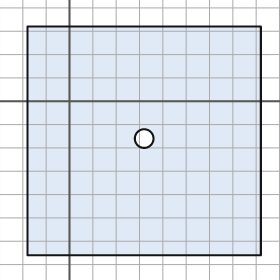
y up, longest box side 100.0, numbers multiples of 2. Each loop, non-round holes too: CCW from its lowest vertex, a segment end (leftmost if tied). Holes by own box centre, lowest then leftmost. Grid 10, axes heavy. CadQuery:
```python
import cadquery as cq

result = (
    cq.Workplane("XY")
    .moveTo(-18.0, -66.0)
    .lineTo(82.0, -66.0)
    .lineTo(82.0, 32.0)
    .lineTo(-18.0, 32.0)
    .close()
    .moveTo(32.0, -16.0)
    .circle(4.0)
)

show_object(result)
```